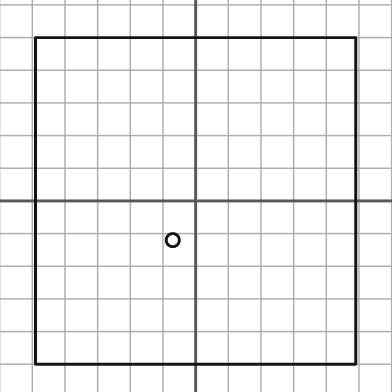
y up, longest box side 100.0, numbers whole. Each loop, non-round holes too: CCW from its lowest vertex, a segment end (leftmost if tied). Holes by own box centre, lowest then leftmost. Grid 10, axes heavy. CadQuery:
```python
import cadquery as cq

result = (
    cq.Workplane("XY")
    .moveTo(-49.0, -50.0)
    .lineTo(49.0, -50.0)
    .lineTo(49.0, 50.0)
    .lineTo(-49.0, 50.0)
    .close()
    .moveTo(-7.0, -12.0)
    .circle(2.0)
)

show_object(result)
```